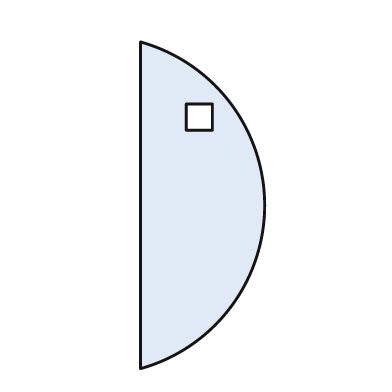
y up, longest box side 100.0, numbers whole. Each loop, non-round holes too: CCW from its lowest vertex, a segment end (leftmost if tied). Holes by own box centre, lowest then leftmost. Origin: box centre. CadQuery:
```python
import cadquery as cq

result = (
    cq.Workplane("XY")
    .moveTo(-19.0, -50.0)
    .threePointArc((19.0, 0.0), (-19.0, 50.0))
    .close()
    .moveTo(-5.0, 23.0)
    .lineTo(3.0, 23.0)
    .lineTo(3.0, 31.0)
    .lineTo(-5.0, 31.0)
    .close()
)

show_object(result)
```